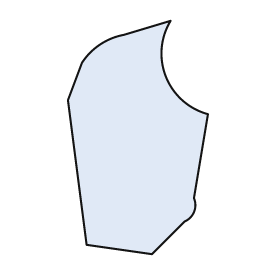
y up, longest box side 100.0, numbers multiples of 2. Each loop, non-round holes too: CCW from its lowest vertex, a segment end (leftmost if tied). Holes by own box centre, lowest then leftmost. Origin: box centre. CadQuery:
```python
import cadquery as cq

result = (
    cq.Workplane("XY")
    .moveTo(6.0, -50.0)
    .lineTo(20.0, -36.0)
    .threePointArc((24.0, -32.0), (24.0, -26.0))
    .lineTo(30.0, 10.0)
    .threePointArc((12.0, 26.0), (14.0, 50.0))
    .lineTo(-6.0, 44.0)
    .threePointArc((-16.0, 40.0), (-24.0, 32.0))
    .lineTo(-30.0, 16.0)
    .lineTo(-22.0, -46.0)
    .close()
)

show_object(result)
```